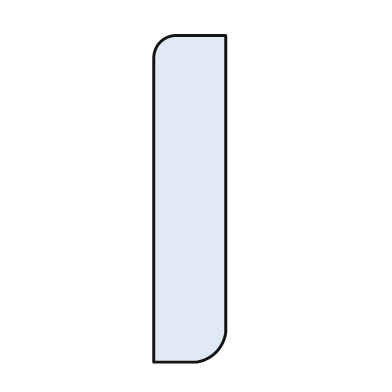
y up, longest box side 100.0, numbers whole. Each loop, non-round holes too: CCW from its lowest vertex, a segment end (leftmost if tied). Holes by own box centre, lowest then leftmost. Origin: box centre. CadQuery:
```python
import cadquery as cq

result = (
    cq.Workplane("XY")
    .moveTo(-11.0, -50.0)
    .lineTo(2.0, -50.0)
    .threePointArc((8.0, -47.0), (11.0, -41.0))
    .lineTo(11.0, 50.0)
    .lineTo(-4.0, 50.0)
    .threePointArc((-9.0, 48.0), (-11.0, 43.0))
    .close()
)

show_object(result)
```